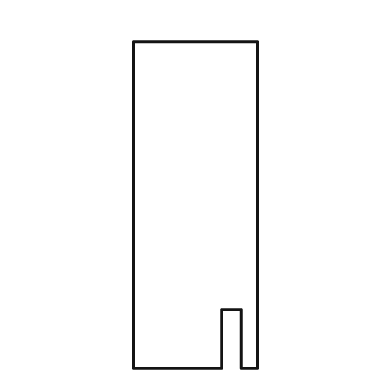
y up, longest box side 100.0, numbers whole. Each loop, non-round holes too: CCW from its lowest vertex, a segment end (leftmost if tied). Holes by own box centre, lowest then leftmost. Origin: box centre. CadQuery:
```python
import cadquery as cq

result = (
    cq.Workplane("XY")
    .moveTo(-19.0, -50.0)
    .lineTo(8.0, -50.0)
    .lineTo(8.0, -32.0)
    .lineTo(14.0, -32.0)
    .lineTo(14.0, -50.0)
    .lineTo(19.0, -50.0)
    .lineTo(19.0, 50.0)
    .lineTo(-19.0, 50.0)
    .close()
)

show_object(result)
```